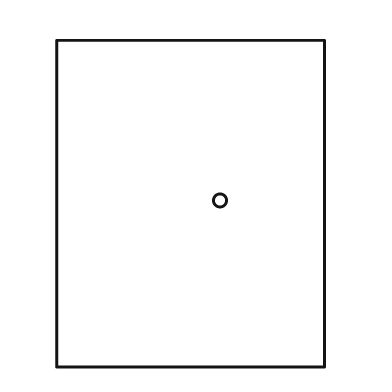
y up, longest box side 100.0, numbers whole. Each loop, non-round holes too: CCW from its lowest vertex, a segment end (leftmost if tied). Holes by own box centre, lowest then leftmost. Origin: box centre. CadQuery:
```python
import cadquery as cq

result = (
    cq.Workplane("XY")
    .moveTo(-41.0, -50.0)
    .lineTo(41.0, -50.0)
    .lineTo(41.0, 50.0)
    .lineTo(-41.0, 50.0)
    .close()
    .moveTo(9.0, 1.0)
    .circle(2.0)
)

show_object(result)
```